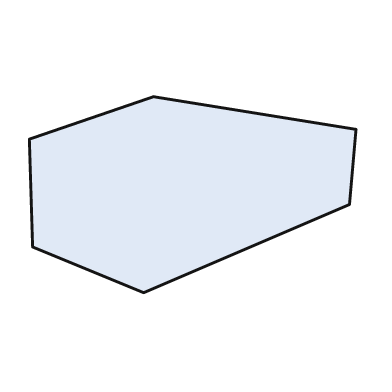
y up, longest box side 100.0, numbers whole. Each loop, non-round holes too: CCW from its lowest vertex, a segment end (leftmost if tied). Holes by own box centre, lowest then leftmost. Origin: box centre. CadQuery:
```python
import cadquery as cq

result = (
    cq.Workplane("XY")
    .moveTo(-15.0, -30.0)
    .lineTo(48.0, -3.0)
    .lineTo(50.0, 20.0)
    .lineTo(-12.0, 30.0)
    .lineTo(-50.0, 17.0)
    .lineTo(-49.0, -16.0)
    .close()
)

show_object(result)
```